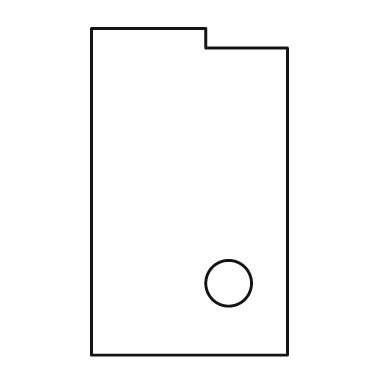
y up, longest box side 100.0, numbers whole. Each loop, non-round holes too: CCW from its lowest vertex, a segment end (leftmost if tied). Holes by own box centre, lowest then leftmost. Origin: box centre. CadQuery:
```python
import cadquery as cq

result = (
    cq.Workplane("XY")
    .moveTo(-30.0, -50.0)
    .lineTo(30.0, -50.0)
    .lineTo(30.0, 44.0)
    .lineTo(5.0, 44.0)
    .lineTo(5.0, 50.0)
    .lineTo(-30.0, 50.0)
    .close()
    .moveTo(12.0, -28.0)
    .circle(7.0)
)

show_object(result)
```